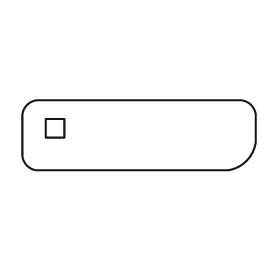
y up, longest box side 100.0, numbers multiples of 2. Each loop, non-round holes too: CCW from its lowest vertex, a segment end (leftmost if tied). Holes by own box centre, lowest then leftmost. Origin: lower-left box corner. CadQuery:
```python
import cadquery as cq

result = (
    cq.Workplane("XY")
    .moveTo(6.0, 0.0)
    .lineTo(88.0, 0.0)
    .threePointArc((96.0, 4.0), (100.0, 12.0))
    .lineTo(100.0, 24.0)
    .threePointArc((98.0, 28.0), (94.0, 30.0))
    .lineTo(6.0, 30.0)
    .threePointArc((2.0, 28.0), (0.0, 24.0))
    .lineTo(0.0, 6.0)
    .threePointArc((2.0, 2.0), (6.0, 0.0))
    .close()
    .moveTo(10.0, 14.0)
    .lineTo(18.0, 14.0)
    .lineTo(18.0, 22.0)
    .lineTo(10.0, 22.0)
    .close()
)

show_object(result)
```